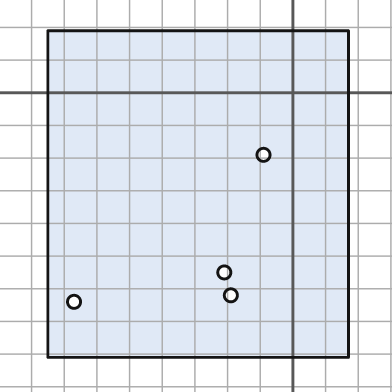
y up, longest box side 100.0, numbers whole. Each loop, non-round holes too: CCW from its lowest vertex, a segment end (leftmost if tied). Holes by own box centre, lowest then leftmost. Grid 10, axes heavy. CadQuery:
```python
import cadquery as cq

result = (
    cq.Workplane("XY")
    .moveTo(-75.0, -81.0)
    .lineTo(17.0, -81.0)
    .lineTo(17.0, 19.0)
    .lineTo(-75.0, 19.0)
    .close()
    .moveTo(-67.0, -64.0)
    .circle(2.0)
    .moveTo(-19.0, -62.0)
    .circle(2.0)
    .moveTo(-21.0, -55.0)
    .circle(2.0)
    .moveTo(-9.0, -19.0)
    .circle(2.0)
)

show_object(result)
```